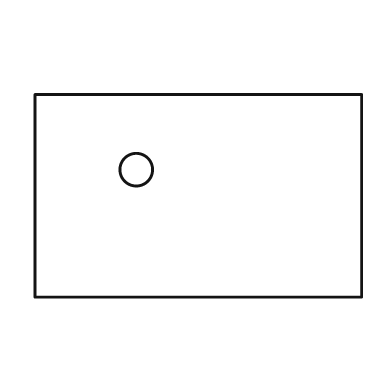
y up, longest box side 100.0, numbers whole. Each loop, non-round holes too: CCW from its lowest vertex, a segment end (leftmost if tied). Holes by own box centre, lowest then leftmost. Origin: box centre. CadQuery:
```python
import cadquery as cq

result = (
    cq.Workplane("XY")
    .moveTo(-50.0, -31.0)
    .lineTo(50.0, -31.0)
    .lineTo(50.0, 31.0)
    .lineTo(-50.0, 31.0)
    .close()
    .moveTo(-19.0, 8.0)
    .circle(5.0)
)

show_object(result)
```